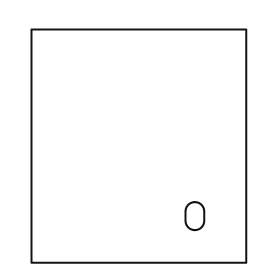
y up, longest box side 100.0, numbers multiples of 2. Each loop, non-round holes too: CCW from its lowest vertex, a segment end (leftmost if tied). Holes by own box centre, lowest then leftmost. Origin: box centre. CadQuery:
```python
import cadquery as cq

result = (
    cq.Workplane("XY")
    .moveTo(-46.0, -50.0)
    .lineTo(46.0, -50.0)
    .lineTo(46.0, 50.0)
    .lineTo(-46.0, 50.0)
    .close()
    .moveTo(20.0, -32.0)
    .threePointArc((24.0, -36.0), (28.0, -32.0))
    .lineTo(28.0, -28.0)
    .threePointArc((24.0, -24.0), (20.0, -28.0))
    .close()
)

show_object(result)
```